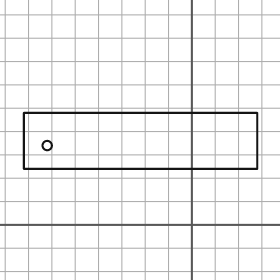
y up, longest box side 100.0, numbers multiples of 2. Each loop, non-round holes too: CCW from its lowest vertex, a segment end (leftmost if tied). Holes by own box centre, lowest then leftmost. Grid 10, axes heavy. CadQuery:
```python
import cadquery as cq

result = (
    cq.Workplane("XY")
    .moveTo(-72.0, 24.0)
    .lineTo(28.0, 24.0)
    .lineTo(28.0, 48.0)
    .lineTo(-72.0, 48.0)
    .close()
    .moveTo(-62.0, 34.0)
    .circle(2.0)
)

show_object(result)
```